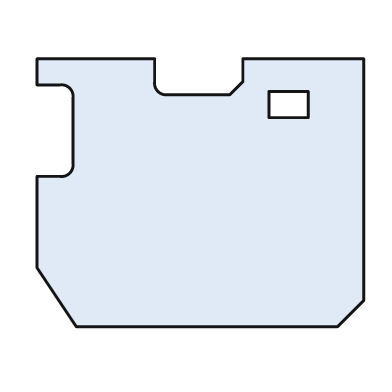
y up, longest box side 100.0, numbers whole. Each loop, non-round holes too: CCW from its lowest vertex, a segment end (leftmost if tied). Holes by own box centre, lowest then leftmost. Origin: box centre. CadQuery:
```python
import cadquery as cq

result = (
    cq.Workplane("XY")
    .moveTo(-38.0, -41.0)
    .lineTo(42.0, -41.0)
    .lineTo(50.0, -33.0)
    .lineTo(50.0, 41.0)
    .lineTo(13.0, 41.0)
    .lineTo(13.0, 34.0)
    .lineTo(9.0, 30.0)
    .lineTo(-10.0, 30.0)
    .threePointArc((-13.0, 31.0), (-14.0, 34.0))
    .lineTo(-14.0, 41.0)
    .lineTo(-50.0, 41.0)
    .lineTo(-50.0, 33.0)
    .lineTo(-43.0, 33.0)
    .threePointArc((-40.0, 32.0), (-39.0, 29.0))
    .lineTo(-39.0, 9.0)
    .threePointArc((-40.0, 6.0), (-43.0, 5.0))
    .lineTo(-50.0, 5.0)
    .lineTo(-50.0, -23.0)
    .close()
    .moveTo(21.0, 23.0)
    .lineTo(33.0, 23.0)
    .lineTo(33.0, 31.0)
    .lineTo(21.0, 31.0)
    .close()
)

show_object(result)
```